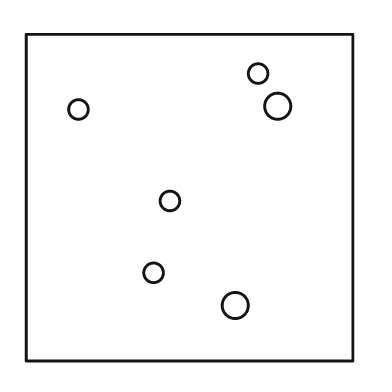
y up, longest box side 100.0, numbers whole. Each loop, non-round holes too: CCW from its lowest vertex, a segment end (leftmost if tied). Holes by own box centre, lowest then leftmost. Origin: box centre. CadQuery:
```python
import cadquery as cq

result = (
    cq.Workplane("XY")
    .moveTo(-50.0, -50.0)
    .lineTo(50.0, -50.0)
    .lineTo(50.0, 50.0)
    .lineTo(-50.0, 50.0)
    .close()
    .moveTo(14.0, -33.0)
    .circle(4.0)
    .moveTo(-11.0, -23.0)
    .circle(3.0)
    .moveTo(-6.0, -1.0)
    .circle(3.0)
    .moveTo(-34.0, 27.0)
    .circle(3.0)
    .moveTo(27.0, 28.0)
    .circle(4.0)
    .moveTo(21.0, 38.0)
    .circle(3.0)
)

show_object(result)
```